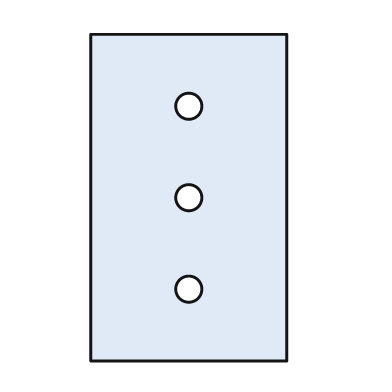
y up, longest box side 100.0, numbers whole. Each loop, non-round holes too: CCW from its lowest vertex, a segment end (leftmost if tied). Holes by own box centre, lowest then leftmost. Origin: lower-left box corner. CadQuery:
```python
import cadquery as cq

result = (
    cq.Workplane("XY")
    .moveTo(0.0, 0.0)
    .lineTo(60.0, 0.0)
    .lineTo(60.0, 100.0)
    .lineTo(0.0, 100.0)
    .close()
    .moveTo(30.0, 22.0)
    .circle(4.0)
    .moveTo(30.0, 50.0)
    .circle(4.0)
    .moveTo(30.0, 78.0)
    .circle(4.0)
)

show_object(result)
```